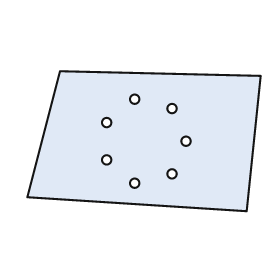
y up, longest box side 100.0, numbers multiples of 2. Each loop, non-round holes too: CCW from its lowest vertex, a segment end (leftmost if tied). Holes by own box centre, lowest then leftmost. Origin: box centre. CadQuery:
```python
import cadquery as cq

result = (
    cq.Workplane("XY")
    .moveTo(44.0, -30.0)
    .lineTo(50.0, 28.0)
    .lineTo(-36.0, 30.0)
    .lineTo(-50.0, -24.0)
    .close()
    .moveTo(-4.0, -18.0)
    .circle(2.0)
    .moveTo(12.0, -14.0)
    .circle(2.0)
    .moveTo(-16.0, -8.0)
    .circle(2.0)
    .moveTo(18.0, 0.0)
    .circle(2.0)
    .moveTo(-16.0, 8.0)
    .circle(2.0)
    .moveTo(12.0, 14.0)
    .circle(2.0)
    .moveTo(-4.0, 18.0)
    .circle(2.0)
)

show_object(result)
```